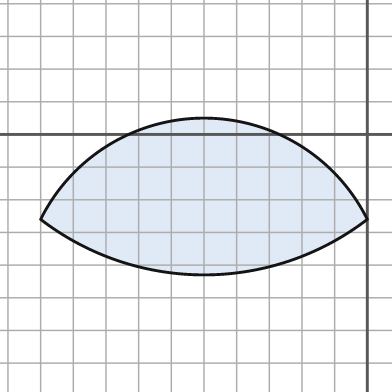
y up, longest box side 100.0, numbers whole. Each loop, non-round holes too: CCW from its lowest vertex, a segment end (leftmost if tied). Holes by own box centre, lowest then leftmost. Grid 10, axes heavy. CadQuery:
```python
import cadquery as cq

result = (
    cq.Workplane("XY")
    .moveTo(-100.0, -26.0)
    .threePointArc((-50.0, -43.0), (0.0, -26.0))
    .threePointArc((-50.0, 5.0), (-100.0, -26.0))
    .close()
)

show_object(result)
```